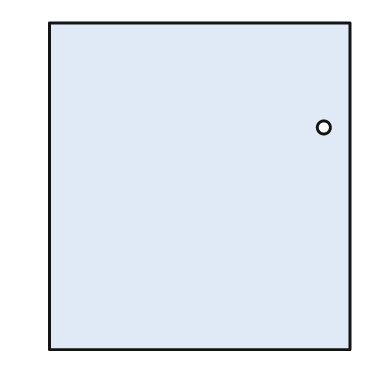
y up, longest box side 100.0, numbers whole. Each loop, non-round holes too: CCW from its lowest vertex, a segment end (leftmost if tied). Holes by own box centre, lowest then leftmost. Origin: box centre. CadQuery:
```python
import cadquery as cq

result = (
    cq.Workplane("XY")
    .moveTo(-46.0, -50.0)
    .lineTo(46.0, -50.0)
    .lineTo(46.0, 50.0)
    .lineTo(-46.0, 50.0)
    .close()
    .moveTo(38.0, 18.0)
    .circle(2.0)
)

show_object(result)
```